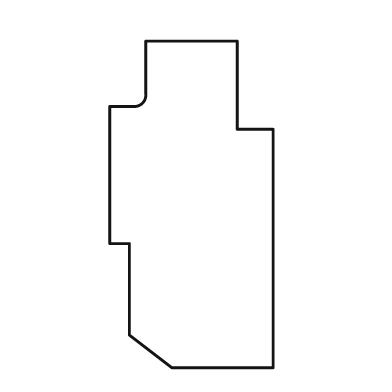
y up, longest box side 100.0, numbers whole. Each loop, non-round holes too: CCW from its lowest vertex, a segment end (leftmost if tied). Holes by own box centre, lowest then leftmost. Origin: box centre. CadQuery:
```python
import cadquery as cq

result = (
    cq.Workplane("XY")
    .moveTo(-6.0, -50.0)
    .lineTo(25.0, -50.0)
    .lineTo(25.0, 23.0)
    .lineTo(14.0, 23.0)
    .lineTo(14.0, 50.0)
    .lineTo(-14.0, 50.0)
    .lineTo(-14.0, 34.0)
    .threePointArc((-15.0, 31.0), (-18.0, 30.0))
    .lineTo(-25.0, 30.0)
    .lineTo(-25.0, -12.0)
    .lineTo(-19.0, -12.0)
    .lineTo(-19.0, -40.0)
    .close()
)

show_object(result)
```